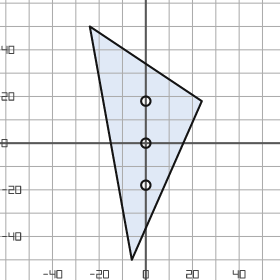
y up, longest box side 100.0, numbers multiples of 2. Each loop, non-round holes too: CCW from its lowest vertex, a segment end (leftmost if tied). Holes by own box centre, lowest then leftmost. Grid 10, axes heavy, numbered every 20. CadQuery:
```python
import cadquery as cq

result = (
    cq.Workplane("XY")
    .moveTo(-6.0, -50.0)
    .lineTo(24.0, 18.0)
    .lineTo(-24.0, 50.0)
    .close()
    .moveTo(0.0, -18.0)
    .circle(2.0)
    .moveTo(0.0, 0.0)
    .circle(2.0)
    .moveTo(0.0, 18.0)
    .circle(2.0)
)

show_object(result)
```